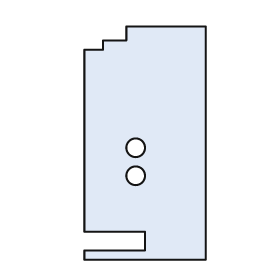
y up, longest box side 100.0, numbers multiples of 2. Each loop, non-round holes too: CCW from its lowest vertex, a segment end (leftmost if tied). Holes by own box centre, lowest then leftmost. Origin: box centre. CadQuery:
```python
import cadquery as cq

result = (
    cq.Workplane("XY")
    .moveTo(-26.0, -50.0)
    .lineTo(26.0, -50.0)
    .lineTo(26.0, 50.0)
    .lineTo(-8.0, 50.0)
    .lineTo(-8.0, 44.0)
    .lineTo(-18.0, 44.0)
    .lineTo(-18.0, 40.0)
    .lineTo(-26.0, 40.0)
    .lineTo(-26.0, -38.0)
    .lineTo(0.0, -38.0)
    .lineTo(0.0, -46.0)
    .lineTo(-26.0, -46.0)
    .close()
    .moveTo(-4.0, -14.0)
    .circle(4.0)
    .moveTo(-4.0, -2.0)
    .circle(4.0)
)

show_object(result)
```